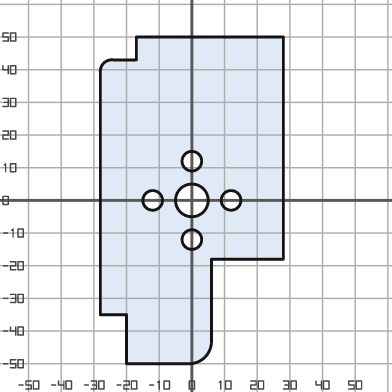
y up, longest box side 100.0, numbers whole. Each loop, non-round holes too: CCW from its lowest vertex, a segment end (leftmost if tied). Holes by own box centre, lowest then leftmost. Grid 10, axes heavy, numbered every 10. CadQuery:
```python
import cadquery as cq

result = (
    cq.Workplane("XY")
    .moveTo(-20.0, -50.0)
    .lineTo(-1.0, -50.0)
    .threePointArc((4.0, -48.0), (6.0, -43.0))
    .lineTo(6.0, -18.0)
    .lineTo(28.0, -18.0)
    .lineTo(28.0, 50.0)
    .lineTo(-17.0, 50.0)
    .lineTo(-17.0, 43.0)
    .lineTo(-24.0, 43.0)
    .threePointArc((-27.0, 42.0), (-28.0, 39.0))
    .lineTo(-28.0, -35.0)
    .lineTo(-20.0, -35.0)
    .close()
    .moveTo(0.0, -12.0)
    .circle(3.0)
    .moveTo(-12.0, 0.0)
    .circle(3.0)
    .moveTo(0.0, 0.0)
    .circle(5.0)
    .moveTo(12.0, 0.0)
    .circle(3.0)
    .moveTo(0.0, 12.0)
    .circle(3.0)
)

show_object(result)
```